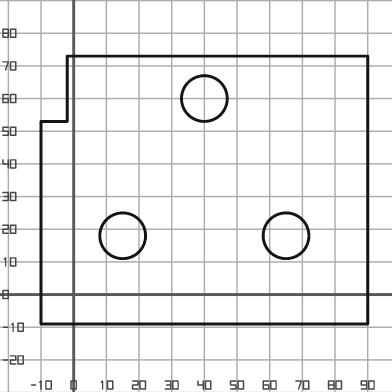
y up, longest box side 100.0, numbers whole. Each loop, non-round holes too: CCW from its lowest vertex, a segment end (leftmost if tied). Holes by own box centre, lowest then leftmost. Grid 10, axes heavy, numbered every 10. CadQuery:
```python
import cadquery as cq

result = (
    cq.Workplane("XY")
    .moveTo(-10.0, -9.0)
    .lineTo(90.0, -9.0)
    .lineTo(90.0, 73.0)
    .lineTo(-2.0, 73.0)
    .lineTo(-2.0, 53.0)
    .lineTo(-10.0, 53.0)
    .close()
    .moveTo(15.0, 18.0)
    .circle(7.0)
    .moveTo(65.0, 18.0)
    .circle(7.0)
    .moveTo(40.0, 60.0)
    .circle(7.0)
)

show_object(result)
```